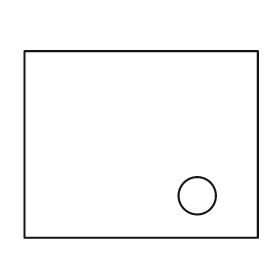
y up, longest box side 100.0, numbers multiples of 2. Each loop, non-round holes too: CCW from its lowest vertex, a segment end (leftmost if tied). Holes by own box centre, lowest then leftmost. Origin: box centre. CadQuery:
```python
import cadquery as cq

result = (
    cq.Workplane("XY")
    .moveTo(-50.0, -40.0)
    .lineTo(50.0, -40.0)
    .lineTo(50.0, 40.0)
    .lineTo(-50.0, 40.0)
    .close()
    .moveTo(24.0, -22.0)
    .circle(8.0)
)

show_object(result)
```